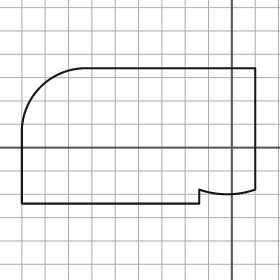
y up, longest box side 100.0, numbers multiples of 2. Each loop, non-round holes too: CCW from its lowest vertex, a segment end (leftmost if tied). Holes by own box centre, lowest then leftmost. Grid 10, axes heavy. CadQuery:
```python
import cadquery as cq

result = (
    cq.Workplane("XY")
    .moveTo(-90.0, -24.0)
    .lineTo(-14.0, -24.0)
    .lineTo(-14.0, -18.0)
    .threePointArc((-2.0, -20.0), (10.0, -18.0))
    .lineTo(10.0, 34.0)
    .lineTo(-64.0, 34.0)
    .threePointArc((-82.0, 26.0), (-90.0, 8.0))
    .close()
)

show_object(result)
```